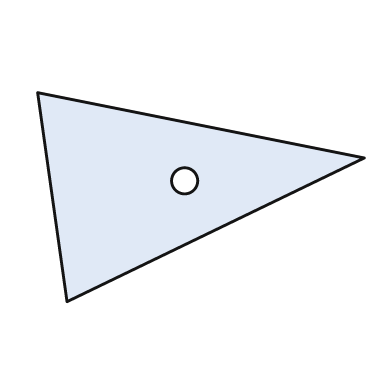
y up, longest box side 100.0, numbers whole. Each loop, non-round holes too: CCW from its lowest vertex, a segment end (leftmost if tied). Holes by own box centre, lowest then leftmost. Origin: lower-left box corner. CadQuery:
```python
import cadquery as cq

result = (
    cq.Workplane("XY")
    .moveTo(9.0, 0.0)
    .lineTo(100.0, 44.0)
    .lineTo(0.0, 64.0)
    .close()
    .moveTo(45.0, 37.0)
    .circle(4.0)
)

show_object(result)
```